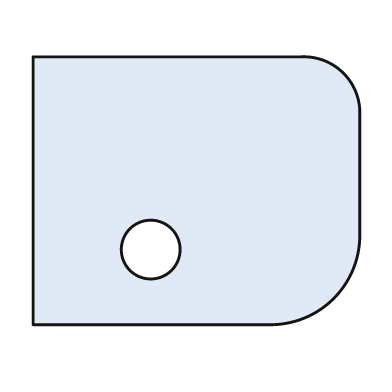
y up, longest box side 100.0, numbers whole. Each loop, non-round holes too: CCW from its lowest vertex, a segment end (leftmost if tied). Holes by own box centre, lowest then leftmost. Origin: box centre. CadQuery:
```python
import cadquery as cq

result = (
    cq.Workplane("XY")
    .moveTo(-50.0, -41.0)
    .lineTo(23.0, -41.0)
    .threePointArc((42.0, -33.0), (50.0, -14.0))
    .lineTo(50.0, 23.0)
    .threePointArc((45.0, 36.0), (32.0, 41.0))
    .lineTo(-50.0, 41.0)
    .close()
    .moveTo(-14.0, -18.0)
    .circle(9.0)
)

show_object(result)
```